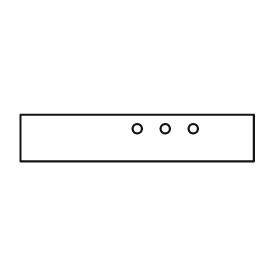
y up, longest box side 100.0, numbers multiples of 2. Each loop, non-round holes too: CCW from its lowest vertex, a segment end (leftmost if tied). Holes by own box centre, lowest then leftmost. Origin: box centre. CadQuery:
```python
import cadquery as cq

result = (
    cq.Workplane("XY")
    .moveTo(-50.0, -10.0)
    .lineTo(50.0, -10.0)
    .lineTo(50.0, 10.0)
    .lineTo(-50.0, 10.0)
    .close()
    .moveTo(0.0, 4.0)
    .circle(2.0)
    .moveTo(12.0, 4.0)
    .circle(2.0)
    .moveTo(24.0, 4.0)
    .circle(2.0)
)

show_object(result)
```